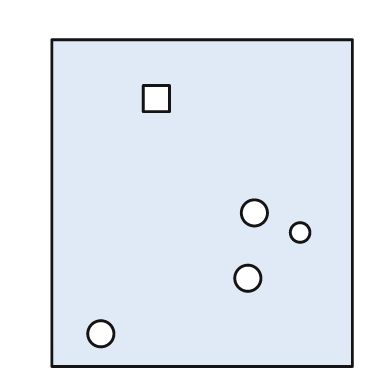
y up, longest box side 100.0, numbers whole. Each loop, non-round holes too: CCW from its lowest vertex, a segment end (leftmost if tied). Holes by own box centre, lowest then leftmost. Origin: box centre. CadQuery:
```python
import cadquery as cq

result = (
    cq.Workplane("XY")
    .moveTo(-46.0, -50.0)
    .lineTo(46.0, -50.0)
    .lineTo(46.0, 50.0)
    .lineTo(-46.0, 50.0)
    .close()
    .moveTo(-31.0, -40.0)
    .circle(4.0)
    .moveTo(14.0, -23.0)
    .circle(4.0)
    .moveTo(30.0, -9.0)
    .circle(3.0)
    .moveTo(16.0, -3.0)
    .circle(4.0)
    .moveTo(-18.0, 28.0)
    .lineTo(-10.0, 28.0)
    .lineTo(-10.0, 36.0)
    .lineTo(-18.0, 36.0)
    .close()
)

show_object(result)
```